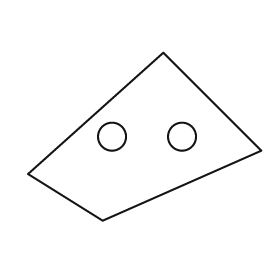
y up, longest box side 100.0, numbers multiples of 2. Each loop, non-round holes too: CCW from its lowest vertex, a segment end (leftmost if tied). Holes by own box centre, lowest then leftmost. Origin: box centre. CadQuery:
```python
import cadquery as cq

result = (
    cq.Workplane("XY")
    .moveTo(-18.0, -36.0)
    .lineTo(50.0, -6.0)
    .lineTo(8.0, 36.0)
    .lineTo(-50.0, -16.0)
    .close()
    .moveTo(-14.0, 0.0)
    .circle(6.0)
    .moveTo(16.0, 0.0)
    .circle(6.0)
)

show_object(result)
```